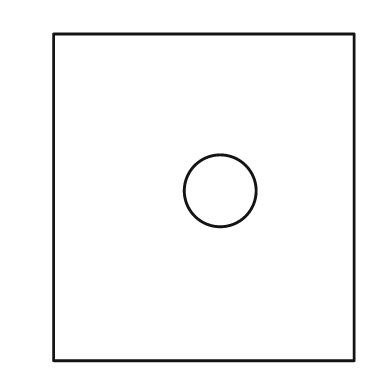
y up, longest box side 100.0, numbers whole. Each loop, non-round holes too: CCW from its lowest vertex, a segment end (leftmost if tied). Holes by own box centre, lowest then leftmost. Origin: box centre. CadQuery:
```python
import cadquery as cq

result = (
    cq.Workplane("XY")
    .moveTo(-46.0, -50.0)
    .lineTo(46.0, -50.0)
    .lineTo(46.0, 50.0)
    .lineTo(-46.0, 50.0)
    .close()
    .moveTo(5.0, 2.0)
    .circle(11.0)
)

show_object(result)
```